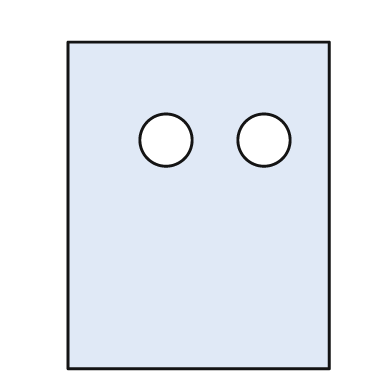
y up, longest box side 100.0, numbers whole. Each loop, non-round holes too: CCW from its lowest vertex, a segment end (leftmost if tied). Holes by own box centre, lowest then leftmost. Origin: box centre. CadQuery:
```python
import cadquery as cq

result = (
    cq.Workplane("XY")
    .moveTo(-40.0, -50.0)
    .lineTo(40.0, -50.0)
    .lineTo(40.0, 50.0)
    .lineTo(-40.0, 50.0)
    .close()
    .moveTo(-10.0, 20.0)
    .circle(8.0)
    .moveTo(20.0, 20.0)
    .circle(8.0)
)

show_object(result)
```